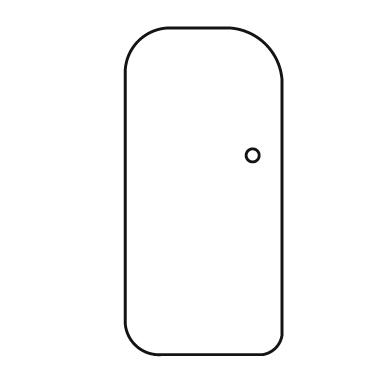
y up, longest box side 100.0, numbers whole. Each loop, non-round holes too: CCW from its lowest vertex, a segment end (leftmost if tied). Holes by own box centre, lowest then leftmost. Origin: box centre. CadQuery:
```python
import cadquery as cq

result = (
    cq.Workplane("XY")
    .moveTo(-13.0, -50.0)
    .lineTo(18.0, -50.0)
    .threePointArc((22.0, -48.0), (24.0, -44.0))
    .lineTo(24.0, 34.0)
    .threePointArc((19.0, 45.0), (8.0, 50.0))
    .lineTo(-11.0, 50.0)
    .threePointArc((-20.0, 46.0), (-24.0, 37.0))
    .lineTo(-24.0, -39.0)
    .threePointArc((-21.0, -47.0), (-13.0, -50.0))
    .close()
    .moveTo(15.0, 11.0)
    .circle(2.0)
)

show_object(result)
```